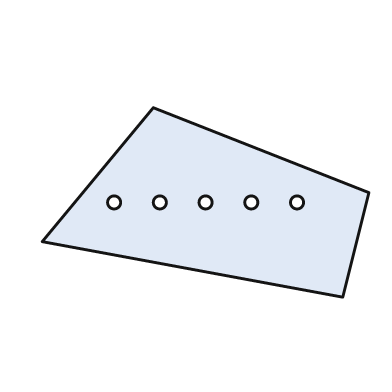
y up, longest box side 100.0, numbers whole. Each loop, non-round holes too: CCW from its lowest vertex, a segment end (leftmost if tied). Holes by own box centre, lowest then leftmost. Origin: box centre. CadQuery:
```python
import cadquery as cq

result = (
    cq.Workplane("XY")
    .moveTo(42.0, -29.0)
    .lineTo(50.0, 3.0)
    .lineTo(-16.0, 29.0)
    .lineTo(-50.0, -12.0)
    .close()
    .moveTo(-28.0, 0.0)
    .circle(2.0)
    .moveTo(-14.0, 0.0)
    .circle(2.0)
    .moveTo(0.0, 0.0)
    .circle(2.0)
    .moveTo(14.0, 0.0)
    .circle(2.0)
    .moveTo(28.0, 0.0)
    .circle(2.0)
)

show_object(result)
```